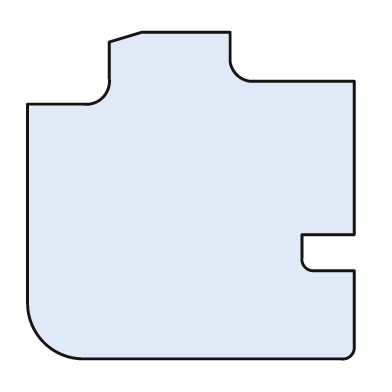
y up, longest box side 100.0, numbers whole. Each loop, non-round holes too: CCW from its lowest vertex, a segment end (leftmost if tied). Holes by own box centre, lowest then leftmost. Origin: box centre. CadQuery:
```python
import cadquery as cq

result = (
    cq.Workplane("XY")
    .moveTo(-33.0, -50.0)
    .lineTo(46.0, -50.0)
    .threePointArc((49.0, -49.0), (50.0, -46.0))
    .lineTo(50.0, -23.0)
    .lineTo(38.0, -23.0)
    .threePointArc((35.0, -22.0), (34.0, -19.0))
    .lineTo(34.0, -12.0)
    .lineTo(50.0, -12.0)
    .lineTo(50.0, 35.0)
    .lineTo(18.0, 35.0)
    .threePointArc((14.0, 37.0), (12.0, 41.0))
    .lineTo(12.0, 50.0)
    .lineTo(-15.0, 50.0)
    .lineTo(-25.0, 47.0)
    .lineTo(-25.0, 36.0)
    .threePointArc((-27.0, 30.0), (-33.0, 28.0))
    .lineTo(-50.0, 28.0)
    .lineTo(-50.0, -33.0)
    .threePointArc((-45.0, -45.0), (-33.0, -50.0))
    .close()
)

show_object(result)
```